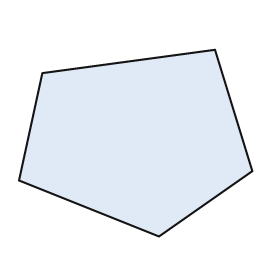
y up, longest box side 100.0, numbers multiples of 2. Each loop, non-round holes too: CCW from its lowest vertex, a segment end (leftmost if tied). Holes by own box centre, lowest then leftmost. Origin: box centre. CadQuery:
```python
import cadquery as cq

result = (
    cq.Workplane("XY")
    .moveTo(10.0, -40.0)
    .lineTo(50.0, -12.0)
    .lineTo(34.0, 40.0)
    .lineTo(-40.0, 30.0)
    .lineTo(-50.0, -16.0)
    .close()
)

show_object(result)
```